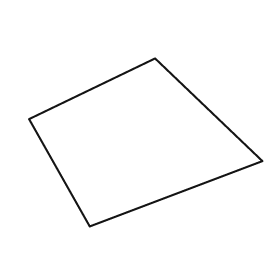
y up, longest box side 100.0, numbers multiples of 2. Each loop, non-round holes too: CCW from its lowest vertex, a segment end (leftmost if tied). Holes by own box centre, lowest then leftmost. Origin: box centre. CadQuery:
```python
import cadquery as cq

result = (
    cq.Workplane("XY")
    .moveTo(-24.0, -36.0)
    .lineTo(50.0, -8.0)
    .lineTo(4.0, 36.0)
    .lineTo(-50.0, 10.0)
    .close()
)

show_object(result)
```